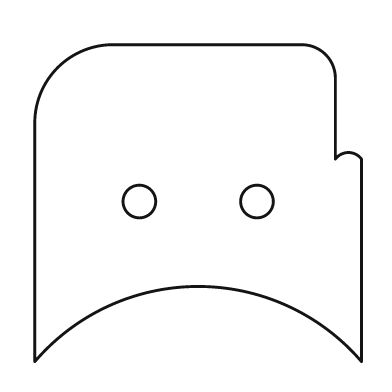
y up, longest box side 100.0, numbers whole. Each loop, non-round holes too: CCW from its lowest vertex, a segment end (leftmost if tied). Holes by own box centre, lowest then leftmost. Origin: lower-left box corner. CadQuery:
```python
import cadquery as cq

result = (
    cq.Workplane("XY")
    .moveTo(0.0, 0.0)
    .threePointArc((50.0, 23.0), (100.0, 0.0))
    .lineTo(100.0, 62.0)
    .threePointArc((96.0, 64.0), (92.0, 62.0))
    .lineTo(92.0, 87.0)
    .threePointArc((89.0, 94.0), (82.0, 97.0))
    .lineTo(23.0, 97.0)
    .threePointArc((7.0, 90.0), (0.0, 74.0))
    .close()
    .moveTo(32.0, 49.0)
    .circle(5.0)
    .moveTo(68.0, 49.0)
    .circle(5.0)
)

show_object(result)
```